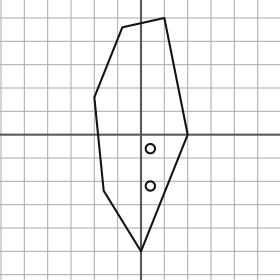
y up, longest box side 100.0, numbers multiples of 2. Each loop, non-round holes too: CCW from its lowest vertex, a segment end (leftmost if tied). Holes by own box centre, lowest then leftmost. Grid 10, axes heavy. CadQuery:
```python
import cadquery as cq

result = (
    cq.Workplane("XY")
    .moveTo(0.0, -50.0)
    .lineTo(20.0, 0.0)
    .lineTo(10.0, 50.0)
    .lineTo(-8.0, 46.0)
    .lineTo(-20.0, 16.0)
    .lineTo(-16.0, -24.0)
    .close()
    .moveTo(4.0, -22.0)
    .circle(2.0)
    .moveTo(4.0, -6.0)
    .circle(2.0)
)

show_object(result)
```